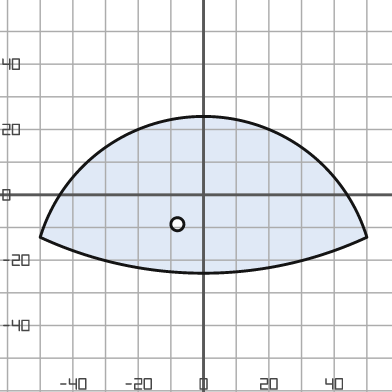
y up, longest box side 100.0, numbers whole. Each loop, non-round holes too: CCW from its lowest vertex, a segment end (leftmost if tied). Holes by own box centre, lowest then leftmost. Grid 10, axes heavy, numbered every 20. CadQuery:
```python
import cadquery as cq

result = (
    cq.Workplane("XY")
    .moveTo(-50.0, -13.0)
    .threePointArc((0.0, -24.0), (50.0, -13.0))
    .threePointArc((0.0, 24.0), (-50.0, -13.0))
    .close()
    .moveTo(-8.0, -9.0)
    .circle(2.0)
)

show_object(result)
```